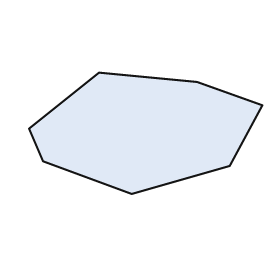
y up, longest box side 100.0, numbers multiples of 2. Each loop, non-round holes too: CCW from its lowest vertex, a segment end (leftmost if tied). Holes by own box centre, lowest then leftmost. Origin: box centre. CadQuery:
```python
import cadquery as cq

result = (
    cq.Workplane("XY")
    .moveTo(-6.0, -26.0)
    .lineTo(36.0, -14.0)
    .lineTo(50.0, 12.0)
    .lineTo(22.0, 22.0)
    .lineTo(-20.0, 26.0)
    .lineTo(-50.0, 2.0)
    .lineTo(-44.0, -12.0)
    .close()
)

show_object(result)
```